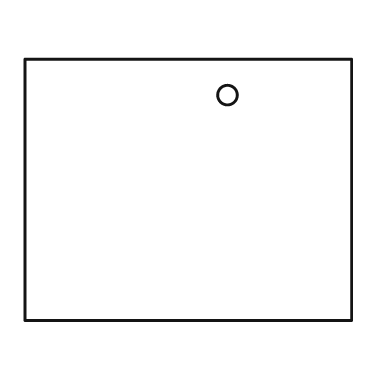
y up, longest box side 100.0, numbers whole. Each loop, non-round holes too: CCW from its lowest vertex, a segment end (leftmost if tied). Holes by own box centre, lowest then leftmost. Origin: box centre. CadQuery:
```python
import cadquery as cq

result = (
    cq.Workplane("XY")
    .moveTo(-50.0, -40.0)
    .lineTo(50.0, -40.0)
    .lineTo(50.0, 40.0)
    .lineTo(-50.0, 40.0)
    .close()
    .moveTo(12.0, 29.0)
    .circle(3.0)
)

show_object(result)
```